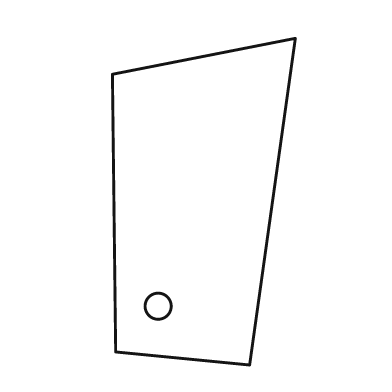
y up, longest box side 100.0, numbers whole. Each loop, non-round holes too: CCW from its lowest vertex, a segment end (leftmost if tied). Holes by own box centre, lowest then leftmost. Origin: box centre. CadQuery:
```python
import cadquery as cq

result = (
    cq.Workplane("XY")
    .moveTo(14.0, -50.0)
    .lineTo(28.0, 50.0)
    .lineTo(-28.0, 39.0)
    .lineTo(-27.0, -46.0)
    .close()
    .moveTo(-14.0, -32.0)
    .circle(4.0)
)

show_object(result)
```